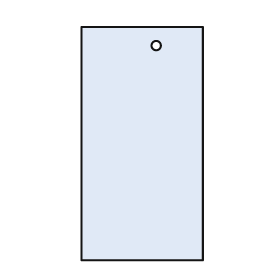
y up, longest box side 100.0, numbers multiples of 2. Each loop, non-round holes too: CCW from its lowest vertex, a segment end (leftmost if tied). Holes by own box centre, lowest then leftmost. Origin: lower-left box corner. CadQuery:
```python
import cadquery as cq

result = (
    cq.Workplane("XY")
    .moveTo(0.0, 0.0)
    .lineTo(52.0, 0.0)
    .lineTo(52.0, 100.0)
    .lineTo(0.0, 100.0)
    .close()
    .moveTo(32.0, 92.0)
    .circle(2.0)
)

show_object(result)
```